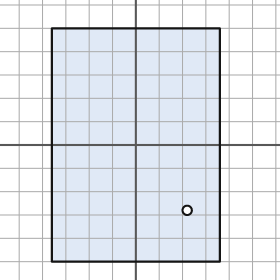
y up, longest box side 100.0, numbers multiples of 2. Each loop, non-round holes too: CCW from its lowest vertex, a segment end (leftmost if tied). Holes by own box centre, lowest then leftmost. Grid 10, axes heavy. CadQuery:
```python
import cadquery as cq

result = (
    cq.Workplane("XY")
    .moveTo(-36.0, -50.0)
    .lineTo(36.0, -50.0)
    .lineTo(36.0, 50.0)
    .lineTo(-36.0, 50.0)
    .close()
    .moveTo(22.0, -28.0)
    .circle(2.0)
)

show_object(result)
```